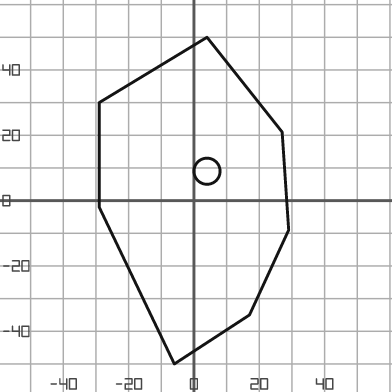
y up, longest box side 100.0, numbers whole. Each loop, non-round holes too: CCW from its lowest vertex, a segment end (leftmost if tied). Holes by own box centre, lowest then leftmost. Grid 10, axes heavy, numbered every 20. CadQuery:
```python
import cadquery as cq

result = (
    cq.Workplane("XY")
    .moveTo(-6.0, -50.0)
    .lineTo(17.0, -35.0)
    .lineTo(29.0, -9.0)
    .lineTo(27.0, 21.0)
    .lineTo(4.0, 50.0)
    .lineTo(-29.0, 30.0)
    .lineTo(-29.0, -2.0)
    .close()
    .moveTo(4.0, 9.0)
    .circle(4.0)
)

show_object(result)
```